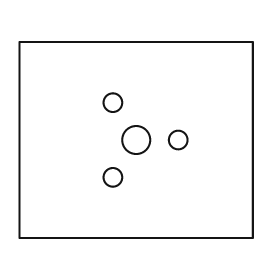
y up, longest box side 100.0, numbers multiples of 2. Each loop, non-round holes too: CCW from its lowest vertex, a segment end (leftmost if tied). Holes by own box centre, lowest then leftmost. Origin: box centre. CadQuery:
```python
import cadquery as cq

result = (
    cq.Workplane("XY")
    .moveTo(-50.0, -42.0)
    .lineTo(50.0, -42.0)
    .lineTo(50.0, 42.0)
    .lineTo(-50.0, 42.0)
    .close()
    .moveTo(-10.0, -16.0)
    .circle(4.0)
    .moveTo(0.0, 0.0)
    .circle(6.0)
    .moveTo(18.0, 0.0)
    .circle(4.0)
    .moveTo(-10.0, 16.0)
    .circle(4.0)
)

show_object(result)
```